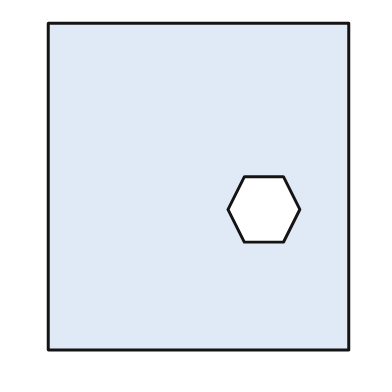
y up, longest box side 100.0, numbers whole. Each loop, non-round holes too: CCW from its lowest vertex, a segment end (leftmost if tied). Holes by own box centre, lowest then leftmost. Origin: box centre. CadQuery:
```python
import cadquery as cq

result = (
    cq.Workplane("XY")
    .moveTo(-46.0, -50.0)
    .lineTo(46.0, -50.0)
    .lineTo(46.0, 50.0)
    .lineTo(-46.0, 50.0)
    .close()
    .moveTo(14.0, -17.0)
    .lineTo(26.0, -17.0)
    .lineTo(31.0, -7.0)
    .lineTo(26.0, 3.0)
    .lineTo(14.0, 3.0)
    .lineTo(9.0, -7.0)
    .close()
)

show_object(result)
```